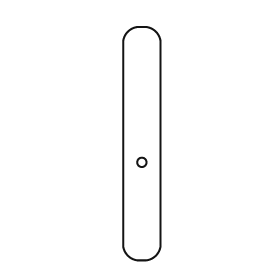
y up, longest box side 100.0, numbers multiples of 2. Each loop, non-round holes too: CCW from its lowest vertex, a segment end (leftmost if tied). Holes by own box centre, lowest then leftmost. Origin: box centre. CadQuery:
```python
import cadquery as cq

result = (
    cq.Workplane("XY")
    .moveTo(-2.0, -50.0)
    .lineTo(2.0, -50.0)
    .threePointArc((6.0, -48.0), (8.0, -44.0))
    .lineTo(8.0, 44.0)
    .threePointArc((6.0, 48.0), (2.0, 50.0))
    .lineTo(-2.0, 50.0)
    .threePointArc((-6.0, 48.0), (-8.0, 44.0))
    .lineTo(-8.0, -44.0)
    .threePointArc((-6.0, -48.0), (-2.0, -50.0))
    .close()
    .moveTo(0.0, -8.0)
    .circle(2.0)
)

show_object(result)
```